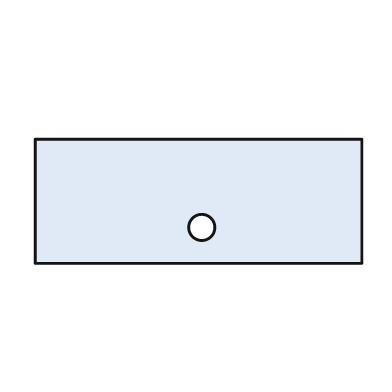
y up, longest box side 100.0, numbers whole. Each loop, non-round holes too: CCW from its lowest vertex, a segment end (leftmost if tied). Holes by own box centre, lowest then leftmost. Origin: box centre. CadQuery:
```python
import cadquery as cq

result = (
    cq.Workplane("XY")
    .moveTo(-50.0, -19.0)
    .lineTo(50.0, -19.0)
    .lineTo(50.0, 19.0)
    .lineTo(-50.0, 19.0)
    .close()
    .moveTo(1.0, -8.0)
    .circle(4.0)
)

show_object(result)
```